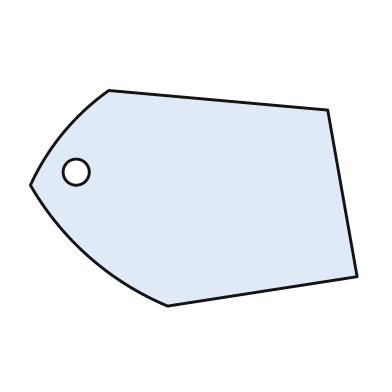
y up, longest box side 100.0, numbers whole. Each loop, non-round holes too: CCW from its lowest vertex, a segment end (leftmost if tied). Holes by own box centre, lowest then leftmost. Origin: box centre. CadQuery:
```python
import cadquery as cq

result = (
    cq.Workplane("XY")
    .moveTo(-8.0, -33.0)
    .lineTo(50.0, -24.0)
    .lineTo(41.0, 27.0)
    .lineTo(-26.0, 33.0)
    .threePointArc((-40.0, 20.0), (-50.0, 4.0))
    .threePointArc((-32.0, -18.0), (-8.0, -33.0))
    .close()
    .moveTo(-36.0, 8.0)
    .circle(4.0)
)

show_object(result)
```